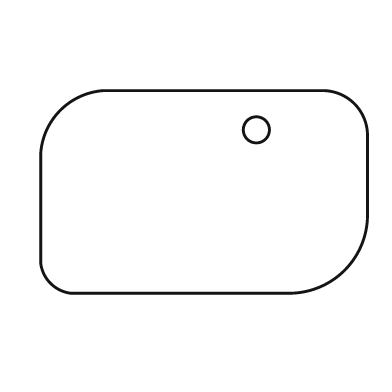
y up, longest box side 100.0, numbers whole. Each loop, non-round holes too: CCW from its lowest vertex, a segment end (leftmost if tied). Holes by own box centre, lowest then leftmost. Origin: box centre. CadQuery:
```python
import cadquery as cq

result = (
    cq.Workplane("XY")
    .moveTo(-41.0, -31.0)
    .lineTo(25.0, -31.0)
    .threePointArc((43.0, -24.0), (50.0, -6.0))
    .lineTo(50.0, 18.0)
    .threePointArc((46.0, 27.0), (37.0, 31.0))
    .lineTo(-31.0, 31.0)
    .threePointArc((-44.0, 25.0), (-50.0, 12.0))
    .lineTo(-50.0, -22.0)
    .threePointArc((-47.0, -28.0), (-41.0, -31.0))
    .close()
    .moveTo(16.0, 19.0)
    .circle(4.0)
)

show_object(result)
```